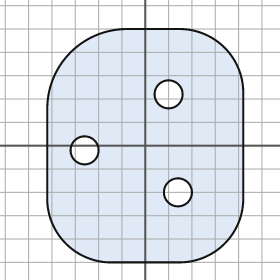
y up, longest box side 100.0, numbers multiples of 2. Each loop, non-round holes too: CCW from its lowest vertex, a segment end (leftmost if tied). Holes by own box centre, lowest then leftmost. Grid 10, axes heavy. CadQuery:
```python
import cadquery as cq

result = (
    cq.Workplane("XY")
    .moveTo(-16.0, -50.0)
    .lineTo(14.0, -50.0)
    .threePointArc((34.0, -42.0), (42.0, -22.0))
    .lineTo(42.0, 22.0)
    .threePointArc((34.0, 42.0), (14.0, 50.0))
    .lineTo(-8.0, 50.0)
    .threePointArc((-32.0, 40.0), (-42.0, 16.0))
    .lineTo(-42.0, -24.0)
    .threePointArc((-34.0, -42.0), (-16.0, -50.0))
    .close()
    .moveTo(14.0, -20.0)
    .circle(6.0)
    .moveTo(-26.0, -2.0)
    .circle(6.0)
    .moveTo(10.0, 22.0)
    .circle(6.0)
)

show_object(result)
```